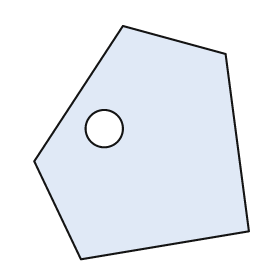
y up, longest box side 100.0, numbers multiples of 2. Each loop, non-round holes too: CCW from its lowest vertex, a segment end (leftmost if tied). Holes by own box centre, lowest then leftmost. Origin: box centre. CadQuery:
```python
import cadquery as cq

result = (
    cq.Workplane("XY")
    .moveTo(-26.0, -50.0)
    .lineTo(46.0, -38.0)
    .lineTo(36.0, 38.0)
    .lineTo(-8.0, 50.0)
    .lineTo(-46.0, -8.0)
    .close()
    .moveTo(-16.0, 6.0)
    .circle(8.0)
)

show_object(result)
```